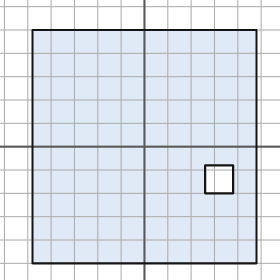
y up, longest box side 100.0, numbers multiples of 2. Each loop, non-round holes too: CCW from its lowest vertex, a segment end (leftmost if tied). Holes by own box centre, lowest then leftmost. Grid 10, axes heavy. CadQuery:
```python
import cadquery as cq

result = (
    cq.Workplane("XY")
    .moveTo(-48.0, -50.0)
    .lineTo(48.0, -50.0)
    .lineTo(48.0, 50.0)
    .lineTo(-48.0, 50.0)
    .close()
    .moveTo(26.0, -20.0)
    .lineTo(38.0, -20.0)
    .lineTo(38.0, -8.0)
    .lineTo(26.0, -8.0)
    .close()
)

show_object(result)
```